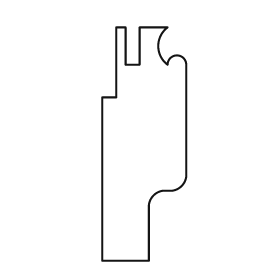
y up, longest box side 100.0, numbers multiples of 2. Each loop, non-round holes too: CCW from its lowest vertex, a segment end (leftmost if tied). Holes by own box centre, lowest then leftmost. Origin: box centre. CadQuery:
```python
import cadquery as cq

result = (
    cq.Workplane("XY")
    .moveTo(-18.0, -50.0)
    .lineTo(2.0, -50.0)
    .lineTo(2.0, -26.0)
    .threePointArc((4.0, -22.0), (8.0, -20.0))
    .lineTo(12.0, -20.0)
    .threePointArc((16.0, -18.0), (18.0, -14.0))
    .lineTo(18.0, 34.0)
    .threePointArc((14.0, 38.0), (10.0, 34.0))
    .threePointArc((6.0, 42.0), (10.0, 50.0))
    .lineTo(-2.0, 50.0)
    .lineTo(-2.0, 34.0)
    .lineTo(-8.0, 34.0)
    .lineTo(-8.0, 50.0)
    .lineTo(-12.0, 50.0)
    .lineTo(-12.0, 20.0)
    .lineTo(-18.0, 20.0)
    .close()
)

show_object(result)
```